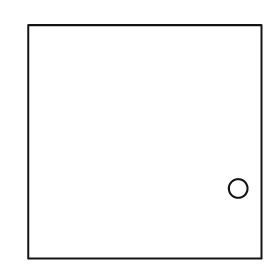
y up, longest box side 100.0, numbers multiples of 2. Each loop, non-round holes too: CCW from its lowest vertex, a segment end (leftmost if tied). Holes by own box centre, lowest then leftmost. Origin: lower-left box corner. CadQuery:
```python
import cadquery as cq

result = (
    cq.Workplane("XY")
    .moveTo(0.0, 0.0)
    .lineTo(100.0, 0.0)
    .lineTo(100.0, 100.0)
    .lineTo(0.0, 100.0)
    .close()
    .moveTo(90.0, 30.0)
    .circle(4.0)
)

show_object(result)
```